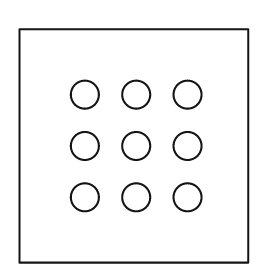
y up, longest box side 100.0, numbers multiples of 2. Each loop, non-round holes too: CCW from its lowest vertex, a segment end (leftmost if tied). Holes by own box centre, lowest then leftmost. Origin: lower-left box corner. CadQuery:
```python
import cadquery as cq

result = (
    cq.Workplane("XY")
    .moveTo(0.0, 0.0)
    .lineTo(98.0, 0.0)
    .lineTo(98.0, 100.0)
    .lineTo(0.0, 100.0)
    .close()
    .moveTo(28.0, 28.0)
    .circle(6.0)
    .moveTo(50.0, 28.0)
    .circle(6.0)
    .moveTo(72.0, 28.0)
    .circle(6.0)
    .moveTo(28.0, 50.0)
    .circle(6.0)
    .moveTo(50.0, 50.0)
    .circle(6.0)
    .moveTo(72.0, 50.0)
    .circle(6.0)
    .moveTo(28.0, 72.0)
    .circle(6.0)
    .moveTo(50.0, 72.0)
    .circle(6.0)
    .moveTo(72.0, 72.0)
    .circle(6.0)
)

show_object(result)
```